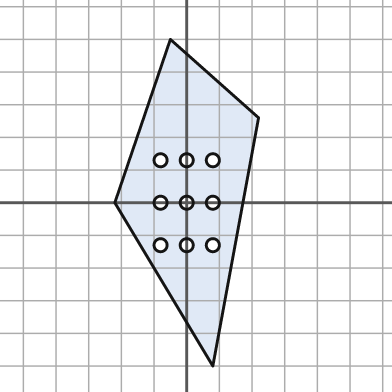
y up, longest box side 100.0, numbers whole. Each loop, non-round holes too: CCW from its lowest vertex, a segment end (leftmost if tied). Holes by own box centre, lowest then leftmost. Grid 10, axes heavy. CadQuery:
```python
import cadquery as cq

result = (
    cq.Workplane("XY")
    .moveTo(8.0, -50.0)
    .lineTo(22.0, 26.0)
    .lineTo(-5.0, 50.0)
    .lineTo(-22.0, 0.0)
    .close()
    .moveTo(-8.0, -13.0)
    .circle(2.0)
    .moveTo(0.0, -13.0)
    .circle(2.0)
    .moveTo(8.0, -13.0)
    .circle(2.0)
    .moveTo(-8.0, 0.0)
    .circle(2.0)
    .moveTo(0.0, 0.0)
    .circle(2.0)
    .moveTo(8.0, 0.0)
    .circle(2.0)
    .moveTo(-8.0, 13.0)
    .circle(2.0)
    .moveTo(0.0, 13.0)
    .circle(2.0)
    .moveTo(8.0, 13.0)
    .circle(2.0)
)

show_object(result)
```